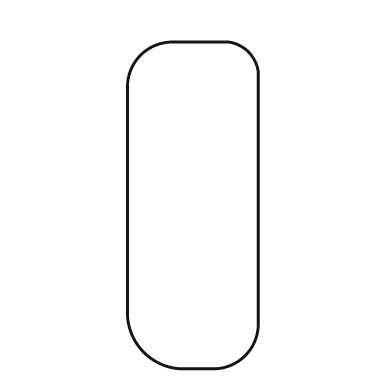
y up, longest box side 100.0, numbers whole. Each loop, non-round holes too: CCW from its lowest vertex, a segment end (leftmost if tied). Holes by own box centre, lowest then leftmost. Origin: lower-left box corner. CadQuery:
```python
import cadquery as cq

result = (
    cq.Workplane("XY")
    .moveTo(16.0, 0.0)
    .lineTo(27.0, 0.0)
    .threePointArc((36.0, 4.0), (40.0, 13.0))
    .lineTo(40.0, 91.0)
    .threePointArc((37.0, 97.0), (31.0, 100.0))
    .lineTo(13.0, 100.0)
    .threePointArc((4.0, 96.0), (0.0, 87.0))
    .lineTo(0.0, 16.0)
    .threePointArc((5.0, 5.0), (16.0, 0.0))
    .close()
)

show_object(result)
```